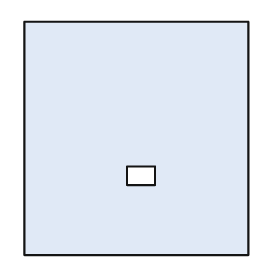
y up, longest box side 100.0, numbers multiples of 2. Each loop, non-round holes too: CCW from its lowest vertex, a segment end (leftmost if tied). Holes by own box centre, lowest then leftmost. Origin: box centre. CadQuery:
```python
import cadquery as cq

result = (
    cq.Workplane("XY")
    .moveTo(-48.0, -50.0)
    .lineTo(48.0, -50.0)
    .lineTo(48.0, 50.0)
    .lineTo(-48.0, 50.0)
    .close()
    .moveTo(-4.0, -20.0)
    .lineTo(8.0, -20.0)
    .lineTo(8.0, -12.0)
    .lineTo(-4.0, -12.0)
    .close()
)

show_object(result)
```